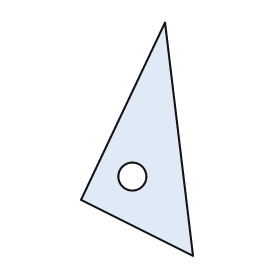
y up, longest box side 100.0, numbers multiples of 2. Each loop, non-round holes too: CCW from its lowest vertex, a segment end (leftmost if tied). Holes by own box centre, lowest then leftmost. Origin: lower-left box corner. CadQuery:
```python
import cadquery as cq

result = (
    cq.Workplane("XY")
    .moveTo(48.0, 0.0)
    .lineTo(36.0, 100.0)
    .lineTo(0.0, 24.0)
    .close()
    .moveTo(22.0, 34.0)
    .circle(6.0)
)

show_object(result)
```